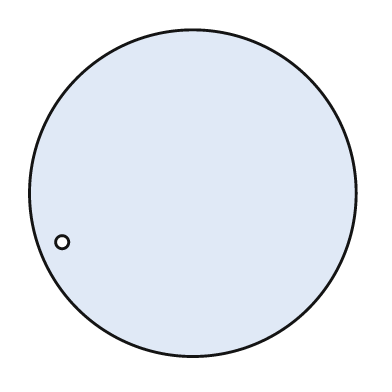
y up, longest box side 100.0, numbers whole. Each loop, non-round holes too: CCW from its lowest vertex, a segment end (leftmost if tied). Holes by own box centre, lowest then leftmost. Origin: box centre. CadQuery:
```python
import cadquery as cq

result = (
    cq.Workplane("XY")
    .moveTo(0.0, 0.0)
    .circle(50.0)
    .moveTo(-40.0, -15.0)
    .circle(2.0)
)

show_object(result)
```